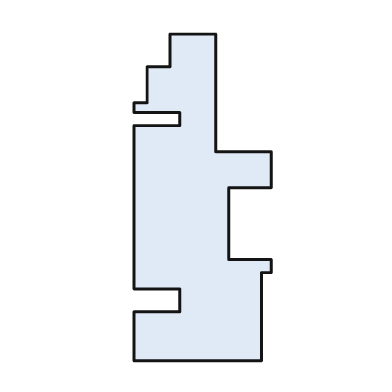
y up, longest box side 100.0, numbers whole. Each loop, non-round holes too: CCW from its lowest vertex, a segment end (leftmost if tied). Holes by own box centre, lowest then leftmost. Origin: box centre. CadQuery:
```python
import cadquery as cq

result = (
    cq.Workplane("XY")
    .moveTo(-21.0, -50.0)
    .lineTo(18.0, -50.0)
    .lineTo(18.0, -23.0)
    .lineTo(21.0, -23.0)
    .lineTo(21.0, -19.0)
    .lineTo(8.0, -19.0)
    .lineTo(8.0, 3.0)
    .lineTo(21.0, 3.0)
    .lineTo(21.0, 14.0)
    .lineTo(4.0, 14.0)
    .lineTo(4.0, 50.0)
    .lineTo(-10.0, 50.0)
    .lineTo(-10.0, 40.0)
    .lineTo(-17.0, 40.0)
    .lineTo(-17.0, 29.0)
    .lineTo(-21.0, 29.0)
    .lineTo(-21.0, 26.0)
    .lineTo(-7.0, 26.0)
    .lineTo(-7.0, 22.0)
    .lineTo(-21.0, 22.0)
    .lineTo(-21.0, -28.0)
    .lineTo(-7.0, -28.0)
    .lineTo(-7.0, -35.0)
    .lineTo(-21.0, -35.0)
    .close()
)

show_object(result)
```